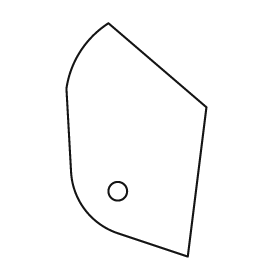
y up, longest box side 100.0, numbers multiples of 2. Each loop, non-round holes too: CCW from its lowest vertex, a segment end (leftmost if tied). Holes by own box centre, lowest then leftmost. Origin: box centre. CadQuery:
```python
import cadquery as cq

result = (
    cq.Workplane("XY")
    .moveTo(22.0, -50.0)
    .lineTo(30.0, 14.0)
    .lineTo(-12.0, 50.0)
    .threePointArc((-24.0, 38.0), (-30.0, 22.0))
    .lineTo(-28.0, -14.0)
    .threePointArc((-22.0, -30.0), (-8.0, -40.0))
    .close()
    .moveTo(-8.0, -22.0)
    .circle(4.0)
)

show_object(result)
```